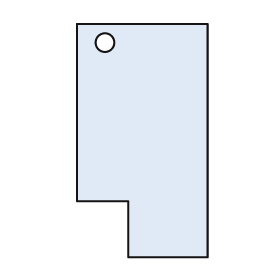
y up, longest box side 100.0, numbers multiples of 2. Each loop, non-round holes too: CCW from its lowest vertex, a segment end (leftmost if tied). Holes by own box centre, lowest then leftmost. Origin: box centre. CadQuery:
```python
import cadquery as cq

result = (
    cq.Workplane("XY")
    .moveTo(-6.0, -50.0)
    .lineTo(28.0, -50.0)
    .lineTo(28.0, 50.0)
    .lineTo(-28.0, 50.0)
    .lineTo(-28.0, -26.0)
    .lineTo(-6.0, -26.0)
    .close()
    .moveTo(-16.0, 42.0)
    .circle(4.0)
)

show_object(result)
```